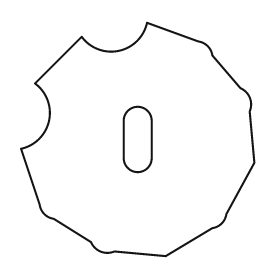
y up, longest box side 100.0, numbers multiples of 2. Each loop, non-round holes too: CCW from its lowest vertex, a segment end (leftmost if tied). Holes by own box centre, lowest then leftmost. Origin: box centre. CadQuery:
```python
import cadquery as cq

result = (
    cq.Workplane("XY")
    .moveTo(12.0, -50.0)
    .lineTo(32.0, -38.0)
    .threePointArc((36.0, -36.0), (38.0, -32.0))
    .lineTo(50.0, -10.0)
    .lineTo(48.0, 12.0)
    .threePointArc((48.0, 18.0), (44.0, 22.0))
    .lineTo(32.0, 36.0)
    .threePointArc((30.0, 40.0), (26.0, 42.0))
    .lineTo(4.0, 50.0)
    .threePointArc((-8.0, 38.0), (-24.0, 44.0))
    .lineTo(-44.0, 24.0)
    .threePointArc((-38.0, 8.0), (-50.0, -4.0))
    .lineTo(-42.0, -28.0)
    .threePointArc((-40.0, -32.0), (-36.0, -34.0))
    .lineTo(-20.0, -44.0)
    .threePointArc((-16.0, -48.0), (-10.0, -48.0))
    .close()
    .moveTo(-6.0, -8.0)
    .threePointArc((0.0, -14.0), (6.0, -8.0))
    .lineTo(6.0, 8.0)
    .threePointArc((0.0, 14.0), (-6.0, 8.0))
    .close()
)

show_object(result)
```